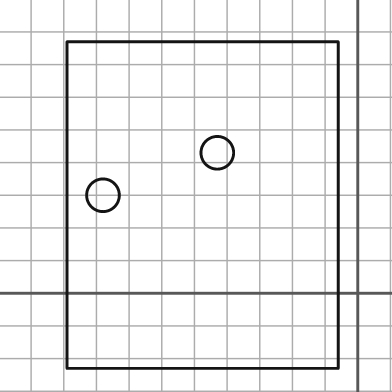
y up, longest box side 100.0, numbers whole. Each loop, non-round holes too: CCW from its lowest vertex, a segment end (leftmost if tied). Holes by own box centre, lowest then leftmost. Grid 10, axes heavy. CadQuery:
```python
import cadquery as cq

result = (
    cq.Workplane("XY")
    .moveTo(-89.0, -23.0)
    .lineTo(-6.0, -23.0)
    .lineTo(-6.0, 77.0)
    .lineTo(-89.0, 77.0)
    .close()
    .moveTo(-78.0, 30.0)
    .circle(5.0)
    .moveTo(-43.0, 43.0)
    .circle(5.0)
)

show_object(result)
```